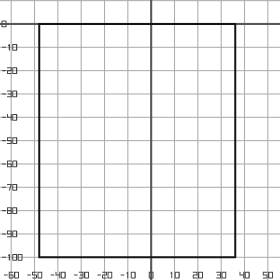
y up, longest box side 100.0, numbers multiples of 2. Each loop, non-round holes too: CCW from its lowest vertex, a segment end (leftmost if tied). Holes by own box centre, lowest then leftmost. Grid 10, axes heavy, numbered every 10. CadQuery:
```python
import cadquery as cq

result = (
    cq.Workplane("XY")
    .moveTo(-48.0, -100.0)
    .lineTo(36.0, -100.0)
    .lineTo(36.0, 0.0)
    .lineTo(-48.0, 0.0)
    .close()
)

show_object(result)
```